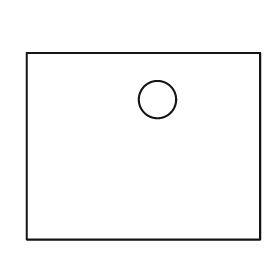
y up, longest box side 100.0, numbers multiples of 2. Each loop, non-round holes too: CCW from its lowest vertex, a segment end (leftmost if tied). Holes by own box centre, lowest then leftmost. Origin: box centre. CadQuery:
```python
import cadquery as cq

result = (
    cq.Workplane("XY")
    .moveTo(-50.0, -40.0)
    .lineTo(50.0, -40.0)
    .lineTo(50.0, 40.0)
    .lineTo(-50.0, 40.0)
    .close()
    .moveTo(6.0, 20.0)
    .circle(8.0)
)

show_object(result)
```